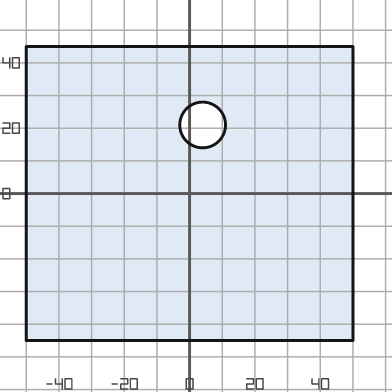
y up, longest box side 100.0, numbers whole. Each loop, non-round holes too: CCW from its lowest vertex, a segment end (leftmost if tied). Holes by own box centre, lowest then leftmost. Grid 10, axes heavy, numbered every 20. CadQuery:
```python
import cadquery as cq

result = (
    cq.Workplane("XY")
    .moveTo(-50.0, -45.0)
    .lineTo(50.0, -45.0)
    .lineTo(50.0, 45.0)
    .lineTo(-50.0, 45.0)
    .close()
    .moveTo(4.0, 21.0)
    .circle(7.0)
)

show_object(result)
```